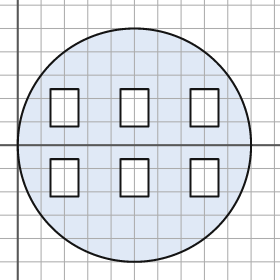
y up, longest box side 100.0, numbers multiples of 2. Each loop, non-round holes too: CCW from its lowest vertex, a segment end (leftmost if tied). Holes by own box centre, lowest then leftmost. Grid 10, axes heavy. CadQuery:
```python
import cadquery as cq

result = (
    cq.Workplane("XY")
    .moveTo(50.0, 0.0)
    .circle(50.0)
    .moveTo(14.0, -22.0)
    .lineTo(26.0, -22.0)
    .lineTo(26.0, -6.0)
    .lineTo(14.0, -6.0)
    .close()
    .moveTo(44.0, -22.0)
    .lineTo(56.0, -22.0)
    .lineTo(56.0, -6.0)
    .lineTo(44.0, -6.0)
    .close()
    .moveTo(74.0, -22.0)
    .lineTo(86.0, -22.0)
    .lineTo(86.0, -6.0)
    .lineTo(74.0, -6.0)
    .close()
    .moveTo(14.0, 8.0)
    .lineTo(26.0, 8.0)
    .lineTo(26.0, 24.0)
    .lineTo(14.0, 24.0)
    .close()
    .moveTo(44.0, 8.0)
    .lineTo(56.0, 8.0)
    .lineTo(56.0, 24.0)
    .lineTo(44.0, 24.0)
    .close()
    .moveTo(74.0, 8.0)
    .lineTo(86.0, 8.0)
    .lineTo(86.0, 24.0)
    .lineTo(74.0, 24.0)
    .close()
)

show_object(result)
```